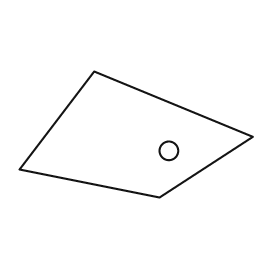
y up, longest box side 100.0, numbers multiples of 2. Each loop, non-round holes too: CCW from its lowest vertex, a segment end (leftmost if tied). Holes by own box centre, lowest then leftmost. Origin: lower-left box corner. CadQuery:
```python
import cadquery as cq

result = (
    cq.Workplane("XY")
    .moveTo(60.0, 0.0)
    .lineTo(100.0, 26.0)
    .lineTo(32.0, 54.0)
    .lineTo(0.0, 12.0)
    .close()
    .moveTo(64.0, 20.0)
    .circle(4.0)
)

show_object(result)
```